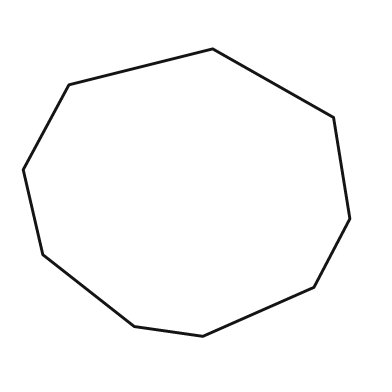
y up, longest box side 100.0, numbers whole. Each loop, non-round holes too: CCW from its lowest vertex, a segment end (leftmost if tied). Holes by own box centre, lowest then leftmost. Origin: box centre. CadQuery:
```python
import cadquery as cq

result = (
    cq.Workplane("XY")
    .moveTo(5.0, -44.0)
    .lineTo(39.0, -29.0)
    .lineTo(50.0, -8.0)
    .lineTo(45.0, 23.0)
    .lineTo(8.0, 44.0)
    .lineTo(-36.0, 33.0)
    .lineTo(-50.0, 7.0)
    .lineTo(-44.0, -19.0)
    .lineTo(-16.0, -41.0)
    .close()
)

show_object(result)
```